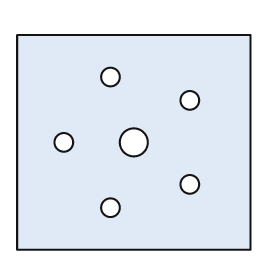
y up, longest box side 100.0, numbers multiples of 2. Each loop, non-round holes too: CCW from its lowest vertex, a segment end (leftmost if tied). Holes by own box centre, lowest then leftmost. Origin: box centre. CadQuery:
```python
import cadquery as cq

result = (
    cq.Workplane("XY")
    .moveTo(-50.0, -46.0)
    .lineTo(50.0, -46.0)
    .lineTo(50.0, 46.0)
    .lineTo(-50.0, 46.0)
    .close()
    .moveTo(-10.0, -28.0)
    .circle(4.0)
    .moveTo(24.0, -18.0)
    .circle(4.0)
    .moveTo(-30.0, 0.0)
    .circle(4.0)
    .moveTo(0.0, 0.0)
    .circle(6.0)
    .moveTo(24.0, 18.0)
    .circle(4.0)
    .moveTo(-10.0, 28.0)
    .circle(4.0)
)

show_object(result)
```